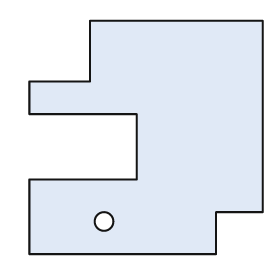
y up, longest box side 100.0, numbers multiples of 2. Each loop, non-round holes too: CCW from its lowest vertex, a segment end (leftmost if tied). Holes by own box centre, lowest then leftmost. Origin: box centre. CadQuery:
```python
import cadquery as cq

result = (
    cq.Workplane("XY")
    .moveTo(-50.0, -50.0)
    .lineTo(30.0, -50.0)
    .lineTo(30.0, -32.0)
    .lineTo(50.0, -32.0)
    .lineTo(50.0, 50.0)
    .lineTo(-24.0, 50.0)
    .lineTo(-24.0, 24.0)
    .lineTo(-50.0, 24.0)
    .lineTo(-50.0, 10.0)
    .lineTo(-4.0, 10.0)
    .lineTo(-4.0, -18.0)
    .lineTo(-50.0, -18.0)
    .close()
    .moveTo(-18.0, -36.0)
    .circle(4.0)
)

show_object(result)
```